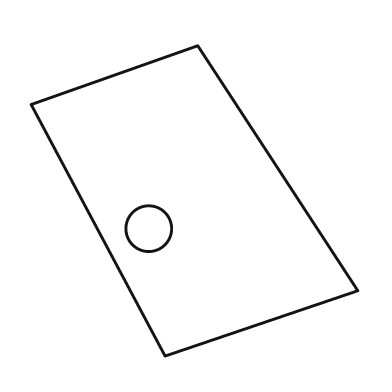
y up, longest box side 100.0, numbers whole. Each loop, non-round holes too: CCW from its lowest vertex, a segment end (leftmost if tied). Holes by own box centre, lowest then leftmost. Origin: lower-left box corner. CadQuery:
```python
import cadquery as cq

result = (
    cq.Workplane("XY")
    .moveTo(41.0, 0.0)
    .lineTo(100.0, 20.0)
    .lineTo(51.0, 95.0)
    .lineTo(0.0, 77.0)
    .close()
    .moveTo(36.0, 39.0)
    .circle(7.0)
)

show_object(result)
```